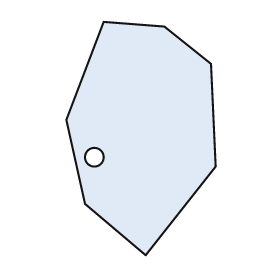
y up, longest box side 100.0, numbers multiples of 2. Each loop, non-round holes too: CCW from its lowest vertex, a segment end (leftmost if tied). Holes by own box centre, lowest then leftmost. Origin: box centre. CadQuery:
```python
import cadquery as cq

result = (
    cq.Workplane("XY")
    .moveTo(2.0, -50.0)
    .lineTo(32.0, -12.0)
    .lineTo(30.0, 32.0)
    .lineTo(10.0, 48.0)
    .lineTo(-16.0, 50.0)
    .lineTo(-32.0, 8.0)
    .lineTo(-24.0, -28.0)
    .close()
    .moveTo(-20.0, -8.0)
    .circle(4.0)
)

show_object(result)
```